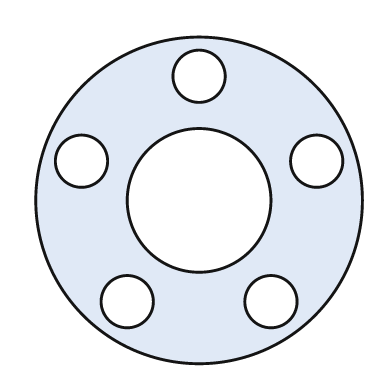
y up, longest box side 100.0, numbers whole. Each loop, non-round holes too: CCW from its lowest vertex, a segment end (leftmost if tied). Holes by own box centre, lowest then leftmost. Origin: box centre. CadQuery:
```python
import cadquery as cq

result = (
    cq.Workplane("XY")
    .moveTo(0.0, 0.0)
    .circle(50.0)
    .moveTo(-22.0, -31.0)
    .circle(8.0)
    .moveTo(22.0, -31.0)
    .circle(8.0)
    .moveTo(0.0, 0.0)
    .circle(22.0)
    .moveTo(-36.0, 12.0)
    .circle(8.0)
    .moveTo(36.0, 12.0)
    .circle(8.0)
    .moveTo(0.0, 38.0)
    .circle(8.0)
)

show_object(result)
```